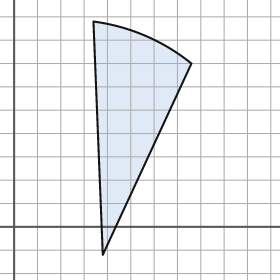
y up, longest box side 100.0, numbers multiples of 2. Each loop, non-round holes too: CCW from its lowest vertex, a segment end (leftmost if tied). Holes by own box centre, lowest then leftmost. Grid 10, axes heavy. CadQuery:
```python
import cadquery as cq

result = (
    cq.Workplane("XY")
    .moveTo(38.0, -12.0)
    .lineTo(76.0, 70.0)
    .threePointArc((56.0, 82.0), (34.0, 88.0))
    .close()
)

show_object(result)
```